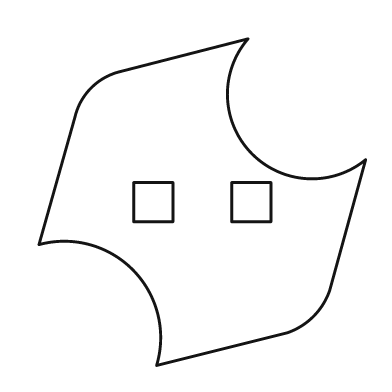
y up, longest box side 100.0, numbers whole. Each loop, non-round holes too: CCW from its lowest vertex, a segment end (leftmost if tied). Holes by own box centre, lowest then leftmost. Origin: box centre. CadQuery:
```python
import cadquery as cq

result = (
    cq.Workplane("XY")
    .moveTo(-14.0, -50.0)
    .lineTo(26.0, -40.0)
    .threePointArc((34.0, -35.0), (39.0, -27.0))
    .lineTo(50.0, 13.0)
    .threePointArc((15.0, 15.0), (14.0, 50.0))
    .lineTo(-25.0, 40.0)
    .threePointArc((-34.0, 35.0), (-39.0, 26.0))
    .lineTo(-50.0, -13.0)
    .threePointArc((-21.0, -21.0), (-14.0, -50.0))
    .close()
    .moveTo(-21.0, -6.0)
    .lineTo(-9.0, -6.0)
    .lineTo(-9.0, 6.0)
    .lineTo(-21.0, 6.0)
    .close()
    .moveTo(9.0, -6.0)
    .lineTo(21.0, -6.0)
    .lineTo(21.0, 6.0)
    .lineTo(9.0, 6.0)
    .close()
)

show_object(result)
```